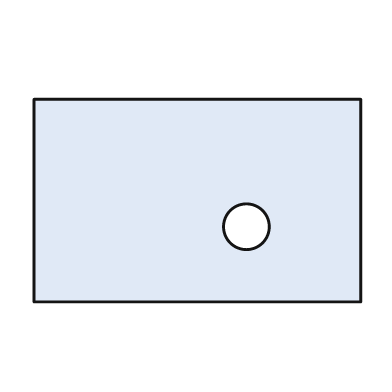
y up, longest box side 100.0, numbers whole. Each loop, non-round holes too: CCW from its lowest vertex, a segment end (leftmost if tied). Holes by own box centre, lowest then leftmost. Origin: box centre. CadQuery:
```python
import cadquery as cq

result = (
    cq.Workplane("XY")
    .moveTo(-50.0, -31.0)
    .lineTo(50.0, -31.0)
    .lineTo(50.0, 31.0)
    .lineTo(-50.0, 31.0)
    .close()
    .moveTo(15.0, -8.0)
    .circle(7.0)
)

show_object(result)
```